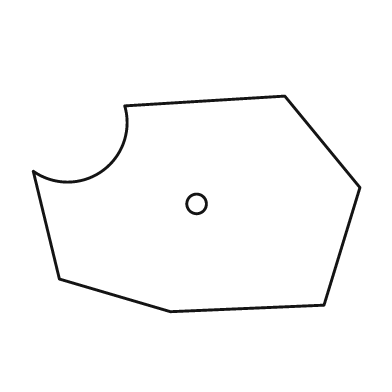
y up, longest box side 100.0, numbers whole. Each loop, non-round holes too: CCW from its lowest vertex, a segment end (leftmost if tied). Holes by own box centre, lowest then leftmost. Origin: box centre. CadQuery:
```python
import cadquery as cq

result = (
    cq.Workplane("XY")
    .moveTo(-8.0, -33.0)
    .lineTo(39.0, -31.0)
    .lineTo(50.0, 5.0)
    .lineTo(27.0, 33.0)
    .lineTo(-22.0, 30.0)
    .threePointArc((-29.0, 10.0), (-50.0, 10.0))
    .lineTo(-42.0, -23.0)
    .close()
    .moveTo(0.0, 0.0)
    .circle(3.0)
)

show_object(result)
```